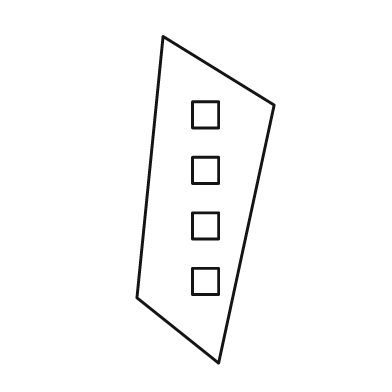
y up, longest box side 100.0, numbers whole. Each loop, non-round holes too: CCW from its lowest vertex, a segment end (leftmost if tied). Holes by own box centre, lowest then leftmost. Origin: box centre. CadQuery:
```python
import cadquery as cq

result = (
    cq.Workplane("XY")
    .moveTo(4.0, -50.0)
    .lineTo(21.0, 29.0)
    .lineTo(-13.0, 50.0)
    .lineTo(-21.0, -30.0)
    .close()
    .moveTo(-4.0, -29.0)
    .lineTo(4.0, -29.0)
    .lineTo(4.0, -21.0)
    .lineTo(-4.0, -21.0)
    .close()
    .moveTo(-4.0, -12.0)
    .lineTo(4.0, -12.0)
    .lineTo(4.0, -4.0)
    .lineTo(-4.0, -4.0)
    .close()
    .moveTo(-4.0, 5.0)
    .lineTo(4.0, 5.0)
    .lineTo(4.0, 13.0)
    .lineTo(-4.0, 13.0)
    .close()
    .moveTo(-4.0, 22.0)
    .lineTo(4.0, 22.0)
    .lineTo(4.0, 30.0)
    .lineTo(-4.0, 30.0)
    .close()
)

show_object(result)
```